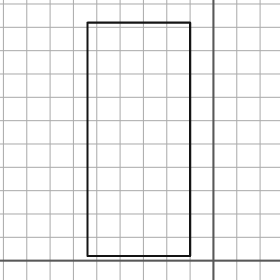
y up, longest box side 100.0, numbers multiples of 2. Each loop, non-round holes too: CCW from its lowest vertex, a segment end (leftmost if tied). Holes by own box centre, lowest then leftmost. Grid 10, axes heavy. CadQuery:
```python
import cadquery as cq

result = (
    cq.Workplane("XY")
    .moveTo(-54.0, 2.0)
    .lineTo(-10.0, 2.0)
    .lineTo(-10.0, 102.0)
    .lineTo(-54.0, 102.0)
    .close()
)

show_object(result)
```